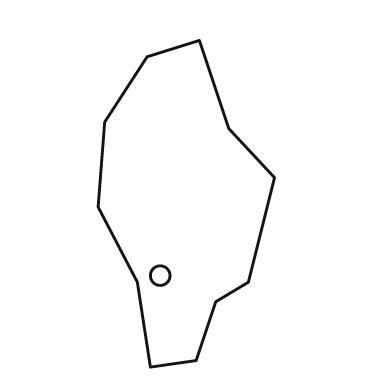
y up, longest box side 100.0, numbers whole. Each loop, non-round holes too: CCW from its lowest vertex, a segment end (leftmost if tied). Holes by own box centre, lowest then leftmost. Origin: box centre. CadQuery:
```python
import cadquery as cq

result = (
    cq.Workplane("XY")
    .moveTo(-11.0, -50.0)
    .lineTo(3.0, -48.0)
    .lineTo(9.0, -30.0)
    .lineTo(19.0, -24.0)
    .lineTo(27.0, 8.0)
    .lineTo(13.0, 23.0)
    .lineTo(4.0, 50.0)
    .lineTo(-12.0, 45.0)
    .lineTo(-25.0, 25.0)
    .lineTo(-27.0, -1.0)
    .lineTo(-15.0, -24.0)
    .close()
    .moveTo(-8.0, -22.0)
    .circle(3.0)
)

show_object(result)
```